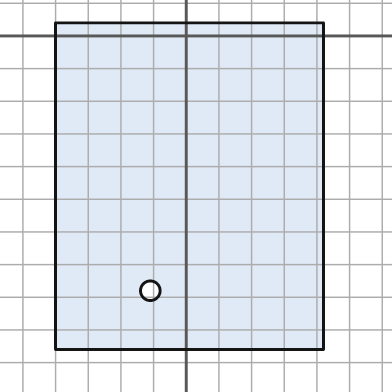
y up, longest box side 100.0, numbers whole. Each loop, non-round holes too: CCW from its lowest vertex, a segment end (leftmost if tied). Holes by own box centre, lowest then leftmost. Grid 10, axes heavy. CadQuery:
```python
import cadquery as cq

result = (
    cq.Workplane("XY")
    .moveTo(-40.0, -96.0)
    .lineTo(42.0, -96.0)
    .lineTo(42.0, 4.0)
    .lineTo(-40.0, 4.0)
    .close()
    .moveTo(-11.0, -78.0)
    .circle(3.0)
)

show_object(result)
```